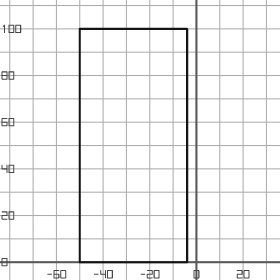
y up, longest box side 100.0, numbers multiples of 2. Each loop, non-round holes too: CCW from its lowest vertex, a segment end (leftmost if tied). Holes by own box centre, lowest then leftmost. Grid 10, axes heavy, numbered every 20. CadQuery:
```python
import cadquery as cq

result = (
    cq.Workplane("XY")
    .moveTo(-50.0, 0.0)
    .lineTo(-4.0, 0.0)
    .lineTo(-4.0, 100.0)
    .lineTo(-50.0, 100.0)
    .close()
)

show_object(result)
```